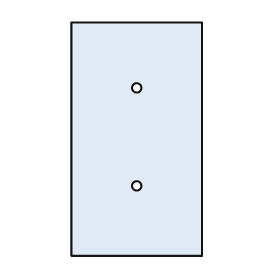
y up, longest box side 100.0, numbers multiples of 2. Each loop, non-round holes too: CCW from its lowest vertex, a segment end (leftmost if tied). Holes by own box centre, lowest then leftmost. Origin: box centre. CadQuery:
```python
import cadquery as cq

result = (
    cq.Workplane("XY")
    .moveTo(-28.0, -50.0)
    .lineTo(28.0, -50.0)
    .lineTo(28.0, 50.0)
    .lineTo(-28.0, 50.0)
    .close()
    .moveTo(0.0, -20.0)
    .circle(2.0)
    .moveTo(0.0, 22.0)
    .circle(2.0)
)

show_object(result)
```